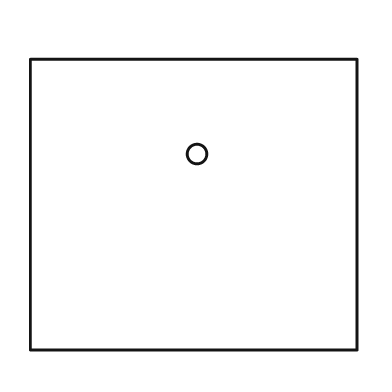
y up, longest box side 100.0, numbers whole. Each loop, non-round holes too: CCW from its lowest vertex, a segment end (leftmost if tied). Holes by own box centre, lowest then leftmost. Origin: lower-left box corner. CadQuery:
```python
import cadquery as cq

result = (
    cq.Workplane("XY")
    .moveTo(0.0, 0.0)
    .lineTo(100.0, 0.0)
    .lineTo(100.0, 89.0)
    .lineTo(0.0, 89.0)
    .close()
    .moveTo(51.0, 60.0)
    .circle(3.0)
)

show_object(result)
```